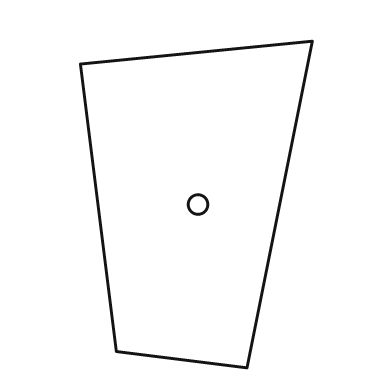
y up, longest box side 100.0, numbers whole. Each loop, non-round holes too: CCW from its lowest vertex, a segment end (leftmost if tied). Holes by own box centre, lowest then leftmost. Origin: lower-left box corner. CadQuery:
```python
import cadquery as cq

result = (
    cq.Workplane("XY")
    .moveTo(51.0, 0.0)
    .lineTo(71.0, 100.0)
    .lineTo(0.0, 93.0)
    .lineTo(11.0, 5.0)
    .close()
    .moveTo(36.0, 50.0)
    .circle(3.0)
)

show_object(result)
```